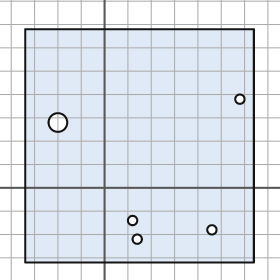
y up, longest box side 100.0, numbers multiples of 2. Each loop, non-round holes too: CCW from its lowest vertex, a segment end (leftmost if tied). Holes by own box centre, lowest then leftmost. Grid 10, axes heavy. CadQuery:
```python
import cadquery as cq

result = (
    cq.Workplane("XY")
    .moveTo(-34.0, -32.0)
    .lineTo(64.0, -32.0)
    .lineTo(64.0, 68.0)
    .lineTo(-34.0, 68.0)
    .close()
    .moveTo(14.0, -22.0)
    .circle(2.0)
    .moveTo(46.0, -18.0)
    .circle(2.0)
    .moveTo(12.0, -14.0)
    .circle(2.0)
    .moveTo(-20.0, 28.0)
    .circle(4.0)
    .moveTo(58.0, 38.0)
    .circle(2.0)
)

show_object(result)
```